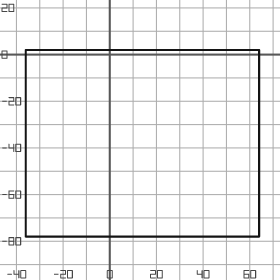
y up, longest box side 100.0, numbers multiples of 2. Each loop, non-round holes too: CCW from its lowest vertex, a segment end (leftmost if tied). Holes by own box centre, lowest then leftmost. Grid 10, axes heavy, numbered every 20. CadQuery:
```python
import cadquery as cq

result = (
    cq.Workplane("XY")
    .moveTo(-36.0, -78.0)
    .lineTo(64.0, -78.0)
    .lineTo(64.0, 2.0)
    .lineTo(-36.0, 2.0)
    .close()
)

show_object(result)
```